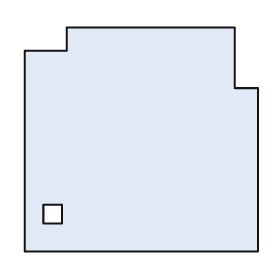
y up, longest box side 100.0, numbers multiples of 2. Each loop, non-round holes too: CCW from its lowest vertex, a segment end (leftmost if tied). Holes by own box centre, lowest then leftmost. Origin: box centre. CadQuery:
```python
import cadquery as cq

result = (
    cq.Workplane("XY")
    .moveTo(-50.0, -48.0)
    .lineTo(50.0, -48.0)
    .lineTo(50.0, 22.0)
    .lineTo(40.0, 22.0)
    .lineTo(40.0, 48.0)
    .lineTo(-32.0, 48.0)
    .lineTo(-32.0, 38.0)
    .lineTo(-50.0, 38.0)
    .close()
    .moveTo(-42.0, -36.0)
    .lineTo(-34.0, -36.0)
    .lineTo(-34.0, -28.0)
    .lineTo(-42.0, -28.0)
    .close()
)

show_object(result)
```